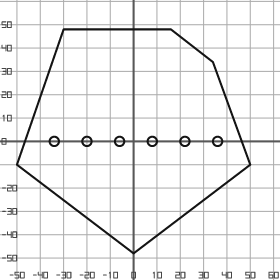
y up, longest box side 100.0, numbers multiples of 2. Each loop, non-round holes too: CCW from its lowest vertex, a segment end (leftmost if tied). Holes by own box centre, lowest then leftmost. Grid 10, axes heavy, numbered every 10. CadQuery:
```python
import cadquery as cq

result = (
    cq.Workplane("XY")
    .moveTo(0.0, -48.0)
    .lineTo(50.0, -10.0)
    .lineTo(34.0, 34.0)
    .lineTo(16.0, 48.0)
    .lineTo(-30.0, 48.0)
    .lineTo(-50.0, -10.0)
    .close()
    .moveTo(-34.0, 0.0)
    .circle(2.0)
    .moveTo(-20.0, 0.0)
    .circle(2.0)
    .moveTo(-6.0, 0.0)
    .circle(2.0)
    .moveTo(8.0, 0.0)
    .circle(2.0)
    .moveTo(22.0, 0.0)
    .circle(2.0)
    .moveTo(36.0, 0.0)
    .circle(2.0)
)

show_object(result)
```